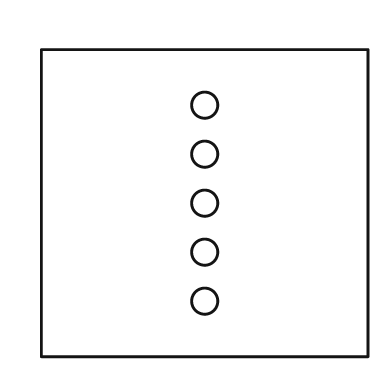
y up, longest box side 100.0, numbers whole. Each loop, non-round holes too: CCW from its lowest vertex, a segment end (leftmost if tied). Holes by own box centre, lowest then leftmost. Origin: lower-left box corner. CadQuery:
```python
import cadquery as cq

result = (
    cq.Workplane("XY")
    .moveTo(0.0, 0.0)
    .lineTo(100.0, 0.0)
    .lineTo(100.0, 94.0)
    .lineTo(0.0, 94.0)
    .close()
    .moveTo(50.0, 17.0)
    .circle(4.0)
    .moveTo(50.0, 32.0)
    .circle(4.0)
    .moveTo(50.0, 47.0)
    .circle(4.0)
    .moveTo(50.0, 62.0)
    .circle(4.0)
    .moveTo(50.0, 77.0)
    .circle(4.0)
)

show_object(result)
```